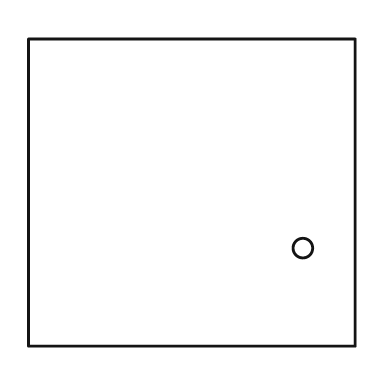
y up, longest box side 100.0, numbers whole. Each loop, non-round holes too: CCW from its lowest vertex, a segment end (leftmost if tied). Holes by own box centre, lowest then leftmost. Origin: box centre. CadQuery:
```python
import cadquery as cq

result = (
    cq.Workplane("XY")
    .moveTo(-50.0, -47.0)
    .lineTo(50.0, -47.0)
    .lineTo(50.0, 47.0)
    .lineTo(-50.0, 47.0)
    .close()
    .moveTo(34.0, -17.0)
    .circle(3.0)
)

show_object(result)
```